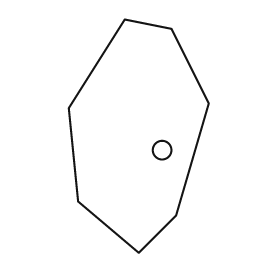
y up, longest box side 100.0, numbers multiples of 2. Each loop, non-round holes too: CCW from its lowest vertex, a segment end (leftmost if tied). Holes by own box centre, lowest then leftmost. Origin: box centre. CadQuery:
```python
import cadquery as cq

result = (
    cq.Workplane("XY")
    .moveTo(0.0, -50.0)
    .lineTo(16.0, -34.0)
    .lineTo(30.0, 14.0)
    .lineTo(14.0, 46.0)
    .lineTo(-6.0, 50.0)
    .lineTo(-30.0, 12.0)
    .lineTo(-26.0, -28.0)
    .close()
    .moveTo(10.0, -6.0)
    .circle(4.0)
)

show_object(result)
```